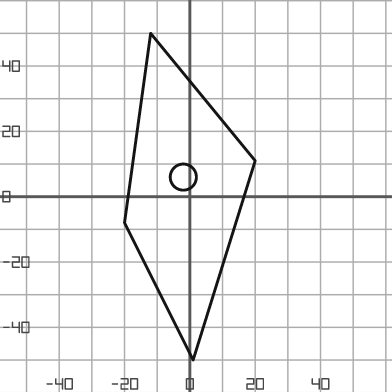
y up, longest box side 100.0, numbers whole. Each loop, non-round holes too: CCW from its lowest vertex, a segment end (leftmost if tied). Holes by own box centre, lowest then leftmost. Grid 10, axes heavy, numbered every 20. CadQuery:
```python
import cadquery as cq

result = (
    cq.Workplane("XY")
    .moveTo(1.0, -50.0)
    .lineTo(20.0, 11.0)
    .lineTo(-12.0, 50.0)
    .lineTo(-20.0, -8.0)
    .close()
    .moveTo(-2.0, 6.0)
    .circle(4.0)
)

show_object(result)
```